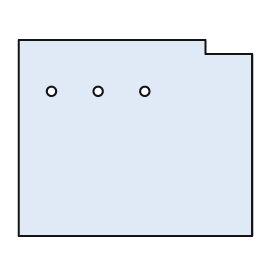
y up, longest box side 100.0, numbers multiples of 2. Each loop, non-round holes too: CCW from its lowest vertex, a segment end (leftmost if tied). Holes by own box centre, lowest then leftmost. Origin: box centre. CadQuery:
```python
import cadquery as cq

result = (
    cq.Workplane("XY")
    .moveTo(-50.0, -42.0)
    .lineTo(50.0, -42.0)
    .lineTo(50.0, 36.0)
    .lineTo(30.0, 36.0)
    .lineTo(30.0, 42.0)
    .lineTo(-50.0, 42.0)
    .close()
    .moveTo(-36.0, 20.0)
    .circle(2.0)
    .moveTo(-16.0, 20.0)
    .circle(2.0)
    .moveTo(4.0, 20.0)
    .circle(2.0)
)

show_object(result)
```